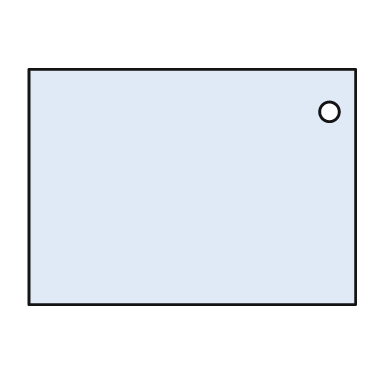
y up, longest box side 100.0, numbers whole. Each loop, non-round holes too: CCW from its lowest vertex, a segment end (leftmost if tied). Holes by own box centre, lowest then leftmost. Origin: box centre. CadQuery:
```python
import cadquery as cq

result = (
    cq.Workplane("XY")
    .moveTo(-50.0, -36.0)
    .lineTo(50.0, -36.0)
    .lineTo(50.0, 36.0)
    .lineTo(-50.0, 36.0)
    .close()
    .moveTo(42.0, 23.0)
    .circle(3.0)
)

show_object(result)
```